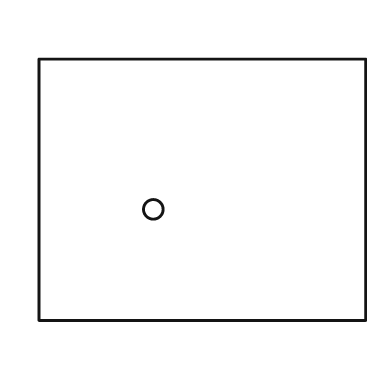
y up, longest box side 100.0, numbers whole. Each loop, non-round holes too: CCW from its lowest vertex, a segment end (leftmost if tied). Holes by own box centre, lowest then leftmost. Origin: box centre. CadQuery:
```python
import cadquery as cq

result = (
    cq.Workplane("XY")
    .moveTo(-50.0, -40.0)
    .lineTo(50.0, -40.0)
    .lineTo(50.0, 40.0)
    .lineTo(-50.0, 40.0)
    .close()
    .moveTo(-15.0, -6.0)
    .circle(3.0)
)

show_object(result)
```